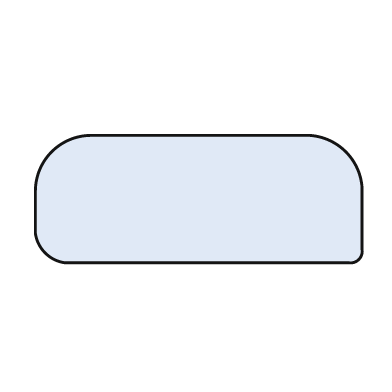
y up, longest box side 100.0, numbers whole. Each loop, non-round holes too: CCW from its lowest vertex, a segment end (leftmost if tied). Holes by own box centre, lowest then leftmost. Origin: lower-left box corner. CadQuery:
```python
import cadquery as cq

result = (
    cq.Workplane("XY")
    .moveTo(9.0, 0.0)
    .lineTo(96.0, 0.0)
    .threePointArc((99.0, 1.0), (100.0, 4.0))
    .lineTo(100.0, 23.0)
    .threePointArc((95.0, 34.0), (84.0, 39.0))
    .lineTo(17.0, 39.0)
    .threePointArc((5.0, 34.0), (0.0, 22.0))
    .lineTo(0.0, 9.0)
    .threePointArc((3.0, 3.0), (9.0, 0.0))
    .close()
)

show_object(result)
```